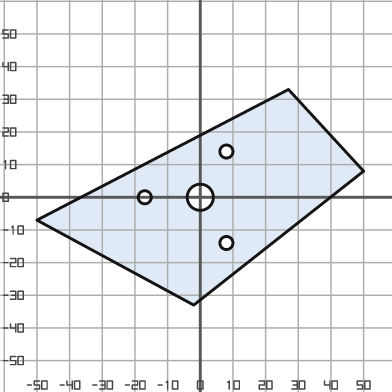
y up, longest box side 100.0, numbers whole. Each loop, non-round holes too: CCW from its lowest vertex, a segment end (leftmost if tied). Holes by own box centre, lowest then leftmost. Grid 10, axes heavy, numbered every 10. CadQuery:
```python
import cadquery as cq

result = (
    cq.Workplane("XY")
    .moveTo(-2.0, -33.0)
    .lineTo(50.0, 8.0)
    .lineTo(27.0, 33.0)
    .lineTo(-50.0, -7.0)
    .close()
    .moveTo(8.0, -14.0)
    .circle(2.0)
    .moveTo(-17.0, 0.0)
    .circle(2.0)
    .moveTo(0.0, 0.0)
    .circle(4.0)
    .moveTo(8.0, 14.0)
    .circle(2.0)
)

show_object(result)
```